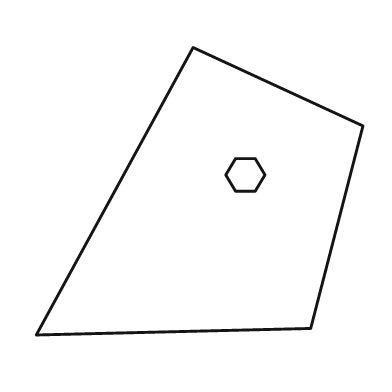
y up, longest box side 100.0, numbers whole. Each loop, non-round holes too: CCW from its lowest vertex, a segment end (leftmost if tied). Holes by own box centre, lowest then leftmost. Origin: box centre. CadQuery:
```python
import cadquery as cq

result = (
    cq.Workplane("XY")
    .moveTo(-50.0, -44.0)
    .lineTo(34.0, -42.0)
    .lineTo(50.0, 20.0)
    .lineTo(-2.0, 44.0)
    .close()
    .moveTo(11.0, 0.0)
    .lineTo(17.0, 0.0)
    .lineTo(20.0, 5.0)
    .lineTo(17.0, 10.0)
    .lineTo(11.0, 10.0)
    .lineTo(8.0, 5.0)
    .close()
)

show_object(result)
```